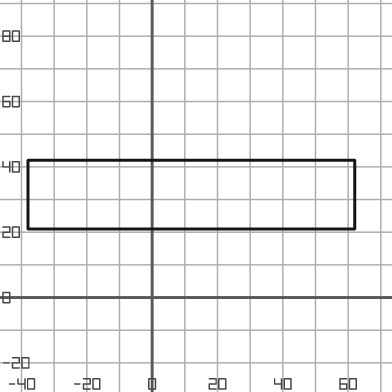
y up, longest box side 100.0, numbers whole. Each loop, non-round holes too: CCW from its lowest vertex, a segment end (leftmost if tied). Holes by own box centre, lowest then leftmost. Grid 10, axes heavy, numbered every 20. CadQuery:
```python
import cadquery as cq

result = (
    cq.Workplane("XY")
    .moveTo(-38.0, 21.0)
    .lineTo(62.0, 21.0)
    .lineTo(62.0, 42.0)
    .lineTo(-38.0, 42.0)
    .close()
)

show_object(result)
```